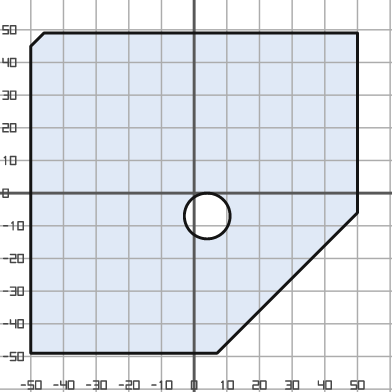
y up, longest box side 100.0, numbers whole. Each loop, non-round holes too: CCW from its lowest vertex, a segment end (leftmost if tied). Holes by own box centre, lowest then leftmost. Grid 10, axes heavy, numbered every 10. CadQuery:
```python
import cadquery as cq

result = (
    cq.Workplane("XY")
    .moveTo(-50.0, -49.0)
    .lineTo(7.0, -49.0)
    .lineTo(50.0, -6.0)
    .lineTo(50.0, 49.0)
    .lineTo(-46.0, 49.0)
    .lineTo(-50.0, 45.0)
    .close()
    .moveTo(4.0, -7.0)
    .circle(7.0)
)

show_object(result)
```